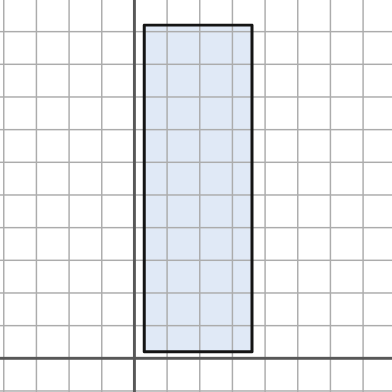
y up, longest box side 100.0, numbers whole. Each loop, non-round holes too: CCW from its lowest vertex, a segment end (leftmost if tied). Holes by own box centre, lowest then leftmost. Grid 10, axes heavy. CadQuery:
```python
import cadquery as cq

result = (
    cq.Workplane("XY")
    .moveTo(3.0, 2.0)
    .lineTo(36.0, 2.0)
    .lineTo(36.0, 102.0)
    .lineTo(3.0, 102.0)
    .close()
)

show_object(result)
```